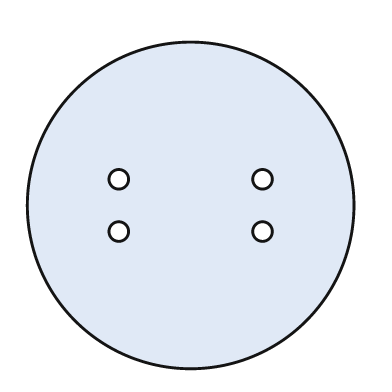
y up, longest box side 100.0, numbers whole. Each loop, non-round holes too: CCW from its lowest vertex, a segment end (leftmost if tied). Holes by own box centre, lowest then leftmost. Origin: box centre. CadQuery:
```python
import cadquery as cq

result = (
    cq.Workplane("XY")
    .moveTo(0.0, 0.0)
    .circle(50.0)
    .moveTo(-22.0, -8.0)
    .circle(3.0)
    .moveTo(22.0, -8.0)
    .circle(3.0)
    .moveTo(-22.0, 8.0)
    .circle(3.0)
    .moveTo(22.0, 8.0)
    .circle(3.0)
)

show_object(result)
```